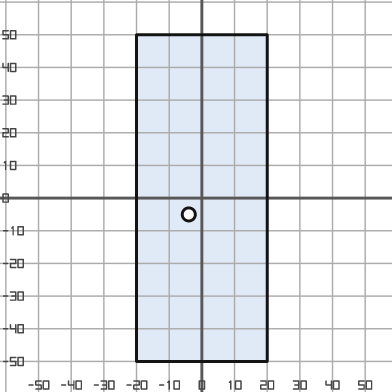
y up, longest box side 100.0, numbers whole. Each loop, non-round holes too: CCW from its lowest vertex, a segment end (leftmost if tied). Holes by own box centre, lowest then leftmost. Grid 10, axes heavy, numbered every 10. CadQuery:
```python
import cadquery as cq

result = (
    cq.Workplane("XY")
    .moveTo(-20.0, -50.0)
    .lineTo(20.0, -50.0)
    .lineTo(20.0, 50.0)
    .lineTo(-20.0, 50.0)
    .close()
    .moveTo(-4.0, -5.0)
    .circle(2.0)
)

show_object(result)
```